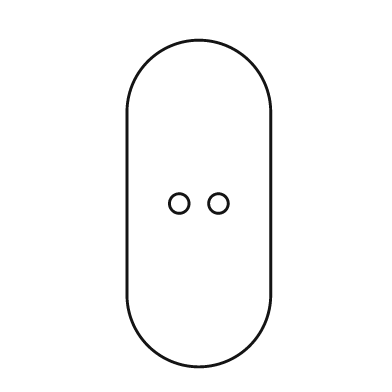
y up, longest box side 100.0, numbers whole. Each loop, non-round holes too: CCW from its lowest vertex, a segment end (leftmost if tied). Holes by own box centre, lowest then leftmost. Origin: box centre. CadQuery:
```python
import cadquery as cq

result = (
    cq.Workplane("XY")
    .moveTo(-22.0, -28.0)
    .threePointArc((0.0, -50.0), (22.0, -28.0))
    .lineTo(22.0, 28.0)
    .threePointArc((0.0, 50.0), (-22.0, 28.0))
    .close()
    .moveTo(-6.0, 0.0)
    .circle(3.0)
    .moveTo(6.0, 0.0)
    .circle(3.0)
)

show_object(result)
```